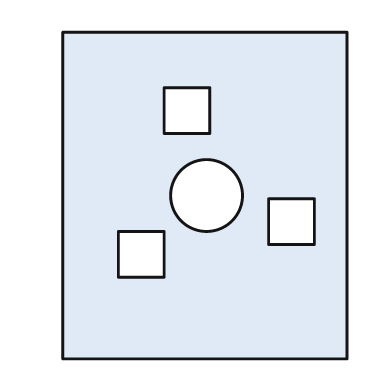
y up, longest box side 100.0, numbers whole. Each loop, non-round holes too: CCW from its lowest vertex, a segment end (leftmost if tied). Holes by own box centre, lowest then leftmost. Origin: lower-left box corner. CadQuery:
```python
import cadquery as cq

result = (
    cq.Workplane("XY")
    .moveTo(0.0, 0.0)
    .lineTo(87.0, 0.0)
    .lineTo(87.0, 100.0)
    .lineTo(0.0, 100.0)
    .close()
    .moveTo(17.0, 25.0)
    .lineTo(31.0, 25.0)
    .lineTo(31.0, 39.0)
    .lineTo(17.0, 39.0)
    .close()
    .moveTo(63.0, 35.0)
    .lineTo(77.0, 35.0)
    .lineTo(77.0, 49.0)
    .lineTo(63.0, 49.0)
    .close()
    .moveTo(44.0, 50.0)
    .circle(11.0)
    .moveTo(31.0, 69.0)
    .lineTo(45.0, 69.0)
    .lineTo(45.0, 83.0)
    .lineTo(31.0, 83.0)
    .close()
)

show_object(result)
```